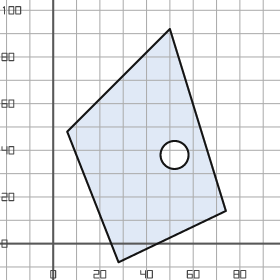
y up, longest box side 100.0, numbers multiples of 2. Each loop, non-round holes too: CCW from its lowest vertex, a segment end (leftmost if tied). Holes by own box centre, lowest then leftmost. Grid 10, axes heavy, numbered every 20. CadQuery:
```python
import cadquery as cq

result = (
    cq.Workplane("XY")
    .moveTo(28.0, -8.0)
    .lineTo(74.0, 14.0)
    .lineTo(50.0, 92.0)
    .lineTo(6.0, 48.0)
    .close()
    .moveTo(52.0, 38.0)
    .circle(6.0)
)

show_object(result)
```